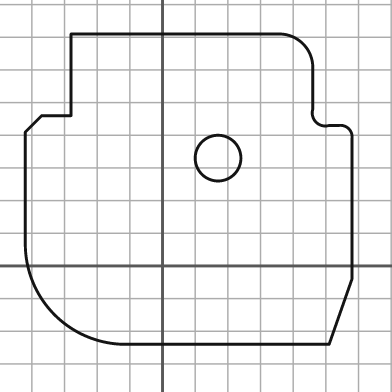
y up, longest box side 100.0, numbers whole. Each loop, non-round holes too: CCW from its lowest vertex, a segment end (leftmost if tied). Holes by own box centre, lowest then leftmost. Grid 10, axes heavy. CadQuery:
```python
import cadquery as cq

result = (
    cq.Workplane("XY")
    .moveTo(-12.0, -24.0)
    .lineTo(51.0, -24.0)
    .lineTo(58.0, -4.0)
    .lineTo(58.0, 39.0)
    .threePointArc((57.0, 42.0), (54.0, 43.0))
    .lineTo(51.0, 43.0)
    .threePointArc((47.0, 44.0), (46.0, 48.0))
    .lineTo(46.0, 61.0)
    .threePointArc((43.0, 68.0), (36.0, 71.0))
    .lineTo(-28.0, 71.0)
    .lineTo(-28.0, 46.0)
    .lineTo(-37.0, 46.0)
    .lineTo(-42.0, 41.0)
    .lineTo(-42.0, 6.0)
    .threePointArc((-33.0, -15.0), (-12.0, -24.0))
    .close()
    .moveTo(17.0, 33.0)
    .circle(7.0)
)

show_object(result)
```